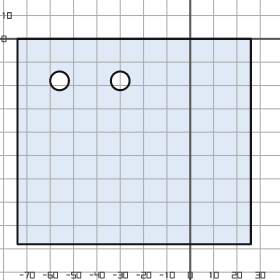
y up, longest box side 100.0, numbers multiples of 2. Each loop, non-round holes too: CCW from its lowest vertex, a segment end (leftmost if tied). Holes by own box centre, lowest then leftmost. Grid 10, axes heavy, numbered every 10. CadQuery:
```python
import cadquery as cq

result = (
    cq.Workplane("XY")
    .moveTo(-74.0, -88.0)
    .lineTo(26.0, -88.0)
    .lineTo(26.0, 0.0)
    .lineTo(-74.0, 0.0)
    .close()
    .moveTo(-56.0, -18.0)
    .circle(4.0)
    .moveTo(-30.0, -18.0)
    .circle(4.0)
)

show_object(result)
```